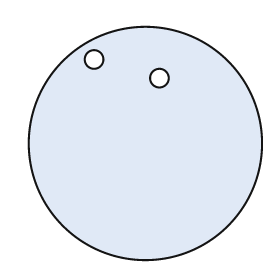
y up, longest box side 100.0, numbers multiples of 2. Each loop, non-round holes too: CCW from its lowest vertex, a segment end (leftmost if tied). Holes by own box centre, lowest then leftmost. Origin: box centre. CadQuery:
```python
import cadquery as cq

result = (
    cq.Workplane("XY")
    .moveTo(0.0, 0.0)
    .circle(50.0)
    .moveTo(6.0, 28.0)
    .circle(4.0)
    .moveTo(-22.0, 36.0)
    .circle(4.0)
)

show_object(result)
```